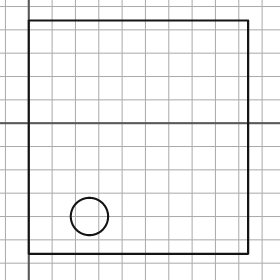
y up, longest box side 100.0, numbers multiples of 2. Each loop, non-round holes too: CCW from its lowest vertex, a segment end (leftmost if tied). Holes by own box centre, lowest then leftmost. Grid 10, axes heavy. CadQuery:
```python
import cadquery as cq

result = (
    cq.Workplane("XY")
    .moveTo(0.0, -56.0)
    .lineTo(94.0, -56.0)
    .lineTo(94.0, 44.0)
    .lineTo(0.0, 44.0)
    .close()
    .moveTo(26.0, -40.0)
    .circle(8.0)
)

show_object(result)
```